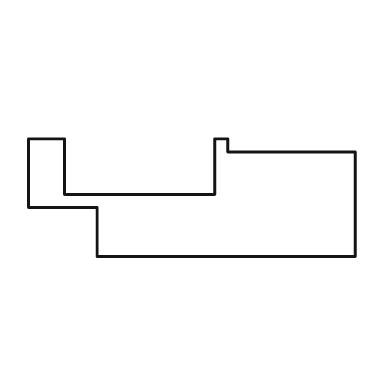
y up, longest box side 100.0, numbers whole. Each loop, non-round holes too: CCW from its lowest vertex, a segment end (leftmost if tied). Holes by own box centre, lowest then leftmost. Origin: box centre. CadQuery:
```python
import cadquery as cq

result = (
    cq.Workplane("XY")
    .moveTo(-29.0, -18.0)
    .lineTo(50.0, -18.0)
    .lineTo(50.0, 14.0)
    .lineTo(11.0, 14.0)
    .lineTo(11.0, 18.0)
    .lineTo(7.0, 18.0)
    .lineTo(7.0, 1.0)
    .lineTo(-39.0, 1.0)
    .lineTo(-39.0, 18.0)
    .lineTo(-50.0, 18.0)
    .lineTo(-50.0, -3.0)
    .lineTo(-29.0, -3.0)
    .close()
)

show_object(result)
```